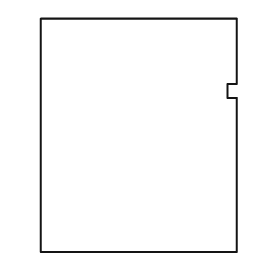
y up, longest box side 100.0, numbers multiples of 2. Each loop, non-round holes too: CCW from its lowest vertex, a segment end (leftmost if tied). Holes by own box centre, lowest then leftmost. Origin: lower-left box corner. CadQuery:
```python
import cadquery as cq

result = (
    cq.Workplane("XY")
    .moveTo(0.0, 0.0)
    .lineTo(84.0, 0.0)
    .lineTo(84.0, 66.0)
    .lineTo(80.0, 66.0)
    .lineTo(80.0, 72.0)
    .lineTo(84.0, 72.0)
    .lineTo(84.0, 100.0)
    .lineTo(0.0, 100.0)
    .close()
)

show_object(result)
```